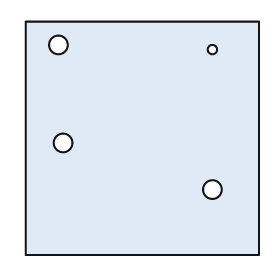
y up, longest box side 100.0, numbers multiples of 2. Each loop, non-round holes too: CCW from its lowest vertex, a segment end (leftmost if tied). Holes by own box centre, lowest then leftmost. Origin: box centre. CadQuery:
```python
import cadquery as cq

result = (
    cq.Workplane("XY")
    .moveTo(-50.0, -50.0)
    .lineTo(50.0, -50.0)
    .lineTo(50.0, 50.0)
    .lineTo(-50.0, 50.0)
    .close()
    .moveTo(30.0, -22.0)
    .circle(4.0)
    .moveTo(-34.0, -2.0)
    .circle(4.0)
    .moveTo(30.0, 38.0)
    .circle(2.0)
    .moveTo(-36.0, 40.0)
    .circle(4.0)
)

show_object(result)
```